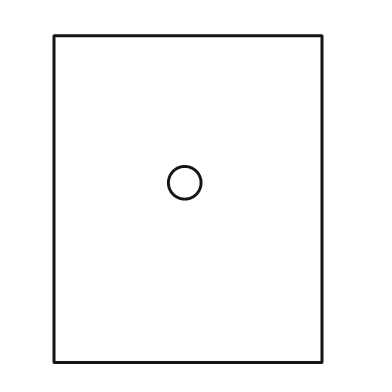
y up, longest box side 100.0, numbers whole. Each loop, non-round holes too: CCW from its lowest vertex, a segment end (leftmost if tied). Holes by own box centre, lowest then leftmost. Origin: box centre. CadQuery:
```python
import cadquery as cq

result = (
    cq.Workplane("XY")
    .moveTo(-41.0, -50.0)
    .lineTo(41.0, -50.0)
    .lineTo(41.0, 50.0)
    .lineTo(-41.0, 50.0)
    .close()
    .moveTo(-1.0, 5.0)
    .circle(5.0)
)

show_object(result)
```